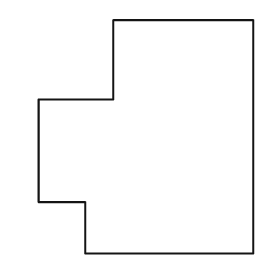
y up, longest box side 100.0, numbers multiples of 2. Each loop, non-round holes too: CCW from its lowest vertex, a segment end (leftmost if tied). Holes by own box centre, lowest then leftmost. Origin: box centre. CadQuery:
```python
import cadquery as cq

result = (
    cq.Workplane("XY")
    .moveTo(-26.0, -50.0)
    .lineTo(46.0, -50.0)
    .lineTo(46.0, 50.0)
    .lineTo(-14.0, 50.0)
    .lineTo(-14.0, 16.0)
    .lineTo(-46.0, 16.0)
    .lineTo(-46.0, -28.0)
    .lineTo(-26.0, -28.0)
    .close()
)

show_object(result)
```